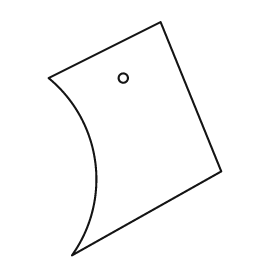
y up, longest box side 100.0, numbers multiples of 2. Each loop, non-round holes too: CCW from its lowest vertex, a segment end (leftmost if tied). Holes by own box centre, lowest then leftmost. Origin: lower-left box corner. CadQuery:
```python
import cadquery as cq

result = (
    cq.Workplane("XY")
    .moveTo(10.0, 0.0)
    .lineTo(74.0, 36.0)
    .lineTo(48.0, 100.0)
    .lineTo(0.0, 76.0)
    .threePointArc((20.0, 40.0), (10.0, 0.0))
    .close()
    .moveTo(32.0, 76.0)
    .circle(2.0)
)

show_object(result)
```